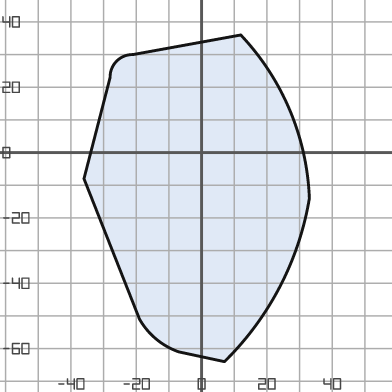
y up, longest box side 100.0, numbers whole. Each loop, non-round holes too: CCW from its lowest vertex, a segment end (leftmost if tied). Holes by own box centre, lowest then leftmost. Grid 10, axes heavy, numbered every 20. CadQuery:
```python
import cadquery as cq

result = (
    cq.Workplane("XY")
    .moveTo(7.0, -64.0)
    .threePointArc((24.0, -41.0), (33.0, -14.0))
    .threePointArc((27.0, 13.0), (12.0, 36.0))
    .lineTo(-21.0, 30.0)
    .threePointArc((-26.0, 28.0), (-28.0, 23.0))
    .lineTo(-36.0, -8.0)
    .lineTo(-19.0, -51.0)
    .threePointArc((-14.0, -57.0), (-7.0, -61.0))
    .close()
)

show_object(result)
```